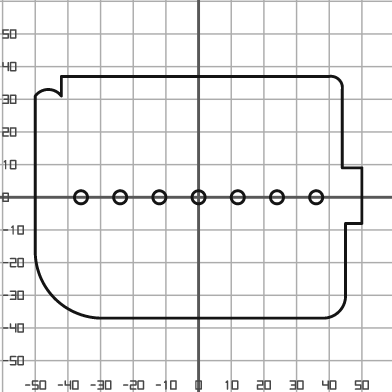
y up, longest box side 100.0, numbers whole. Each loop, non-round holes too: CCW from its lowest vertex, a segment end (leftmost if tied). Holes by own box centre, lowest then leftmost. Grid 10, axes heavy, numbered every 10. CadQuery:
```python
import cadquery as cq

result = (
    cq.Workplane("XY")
    .moveTo(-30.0, -37.0)
    .lineTo(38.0, -37.0)
    .threePointArc((43.0, -35.0), (45.0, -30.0))
    .lineTo(45.0, -8.0)
    .lineTo(50.0, -8.0)
    .lineTo(50.0, 9.0)
    .lineTo(44.0, 9.0)
    .lineTo(44.0, 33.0)
    .threePointArc((43.0, 36.0), (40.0, 37.0))
    .lineTo(-42.0, 37.0)
    .lineTo(-42.0, 31.0)
    .threePointArc((-46.0, 33.0), (-50.0, 31.0))
    .lineTo(-50.0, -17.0)
    .threePointArc((-44.0, -31.0), (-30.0, -37.0))
    .close()
    .moveTo(-36.0, 0.0)
    .circle(2.0)
    .moveTo(-24.0, 0.0)
    .circle(2.0)
    .moveTo(-12.0, 0.0)
    .circle(2.0)
    .moveTo(0.0, 0.0)
    .circle(2.0)
    .moveTo(12.0, 0.0)
    .circle(2.0)
    .moveTo(24.0, 0.0)
    .circle(2.0)
    .moveTo(36.0, 0.0)
    .circle(2.0)
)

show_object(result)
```